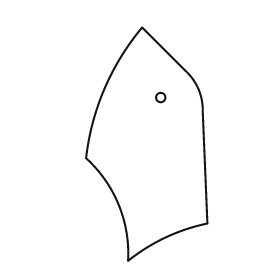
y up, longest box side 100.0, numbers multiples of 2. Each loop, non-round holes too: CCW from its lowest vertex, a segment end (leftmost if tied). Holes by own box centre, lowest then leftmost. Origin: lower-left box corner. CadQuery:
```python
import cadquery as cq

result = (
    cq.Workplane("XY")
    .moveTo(18.0, 0.0)
    .threePointArc((34.0, 10.0), (52.0, 16.0))
    .lineTo(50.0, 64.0)
    .threePointArc((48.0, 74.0), (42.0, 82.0))
    .lineTo(24.0, 100.0)
    .threePointArc((8.0, 74.0), (0.0, 44.0))
    .threePointArc((14.0, 24.0), (18.0, 0.0))
    .close()
    .moveTo(32.0, 70.0)
    .circle(2.0)
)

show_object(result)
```